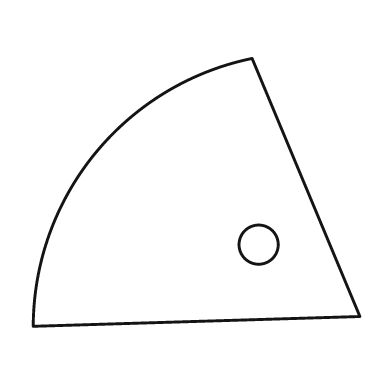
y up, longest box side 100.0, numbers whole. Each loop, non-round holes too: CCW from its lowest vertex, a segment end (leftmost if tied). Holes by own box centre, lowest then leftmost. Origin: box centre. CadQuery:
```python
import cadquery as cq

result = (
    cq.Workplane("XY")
    .moveTo(-50.0, -41.0)
    .lineTo(50.0, -38.0)
    .lineTo(17.0, 41.0)
    .threePointArc((-31.0, 12.0), (-50.0, -41.0))
    .close()
    .moveTo(19.0, -16.0)
    .circle(6.0)
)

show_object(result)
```